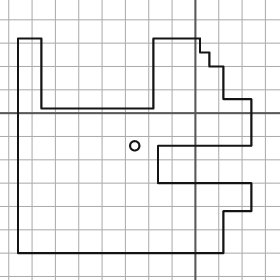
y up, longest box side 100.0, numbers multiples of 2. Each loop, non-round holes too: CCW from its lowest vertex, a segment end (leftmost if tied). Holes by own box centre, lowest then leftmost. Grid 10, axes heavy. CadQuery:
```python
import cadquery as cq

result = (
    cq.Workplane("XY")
    .moveTo(-76.0, -60.0)
    .lineTo(12.0, -60.0)
    .lineTo(12.0, -42.0)
    .lineTo(24.0, -42.0)
    .lineTo(24.0, -30.0)
    .lineTo(-16.0, -30.0)
    .lineTo(-16.0, -14.0)
    .lineTo(24.0, -14.0)
    .lineTo(24.0, 6.0)
    .lineTo(12.0, 6.0)
    .lineTo(12.0, 20.0)
    .lineTo(6.0, 20.0)
    .lineTo(6.0, 26.0)
    .lineTo(2.0, 26.0)
    .lineTo(2.0, 32.0)
    .lineTo(-18.0, 32.0)
    .lineTo(-18.0, 2.0)
    .lineTo(-66.0, 2.0)
    .lineTo(-66.0, 32.0)
    .lineTo(-76.0, 32.0)
    .close()
    .moveTo(-26.0, -14.0)
    .circle(2.0)
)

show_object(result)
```